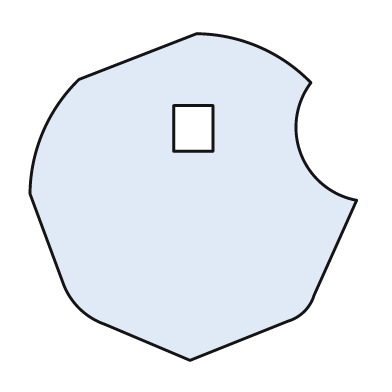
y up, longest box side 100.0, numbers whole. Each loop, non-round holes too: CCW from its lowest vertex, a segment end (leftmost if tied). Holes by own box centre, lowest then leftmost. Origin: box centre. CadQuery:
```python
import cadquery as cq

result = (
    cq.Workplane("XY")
    .moveTo(-1.0, -50.0)
    .lineTo(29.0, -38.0)
    .threePointArc((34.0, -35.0), (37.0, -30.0))
    .lineTo(50.0, -1.0)
    .threePointArc((33.0, 13.0), (36.0, 35.0))
    .threePointArc((20.0, 46.0), (1.0, 50.0))
    .lineTo(-35.0, 36.0)
    .threePointArc((-46.0, 20.0), (-50.0, 1.0))
    .lineTo(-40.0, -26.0)
    .threePointArc((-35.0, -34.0), (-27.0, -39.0))
    .close()
    .moveTo(-6.0, 14.0)
    .lineTo(6.0, 14.0)
    .lineTo(6.0, 28.0)
    .lineTo(-6.0, 28.0)
    .close()
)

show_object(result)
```